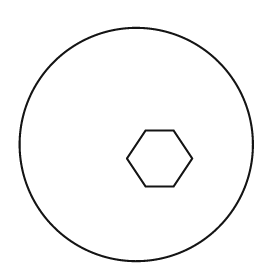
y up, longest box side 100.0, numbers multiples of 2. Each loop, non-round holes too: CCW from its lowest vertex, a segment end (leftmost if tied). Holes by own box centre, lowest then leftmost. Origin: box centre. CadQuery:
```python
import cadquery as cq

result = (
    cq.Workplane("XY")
    .moveTo(0.0, 0.0)
    .circle(50.0)
    .moveTo(4.0, -18.0)
    .lineTo(16.0, -18.0)
    .lineTo(24.0, -6.0)
    .lineTo(16.0, 6.0)
    .lineTo(4.0, 6.0)
    .lineTo(-4.0, -6.0)
    .close()
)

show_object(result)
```